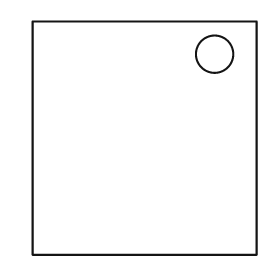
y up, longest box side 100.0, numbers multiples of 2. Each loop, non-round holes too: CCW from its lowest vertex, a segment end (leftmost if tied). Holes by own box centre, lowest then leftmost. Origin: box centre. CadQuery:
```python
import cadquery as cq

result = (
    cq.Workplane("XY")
    .moveTo(-48.0, -50.0)
    .lineTo(48.0, -50.0)
    .lineTo(48.0, 50.0)
    .lineTo(-48.0, 50.0)
    .close()
    .moveTo(30.0, 36.0)
    .circle(8.0)
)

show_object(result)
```